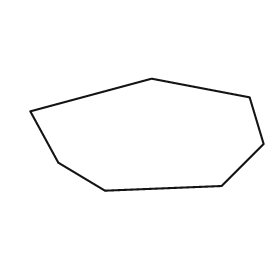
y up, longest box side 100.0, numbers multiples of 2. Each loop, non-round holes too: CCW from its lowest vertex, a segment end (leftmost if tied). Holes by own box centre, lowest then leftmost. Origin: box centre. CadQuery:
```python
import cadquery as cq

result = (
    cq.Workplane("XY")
    .moveTo(-18.0, -24.0)
    .lineTo(32.0, -22.0)
    .lineTo(50.0, -4.0)
    .lineTo(44.0, 16.0)
    .lineTo(2.0, 24.0)
    .lineTo(-50.0, 10.0)
    .lineTo(-38.0, -12.0)
    .close()
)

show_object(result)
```